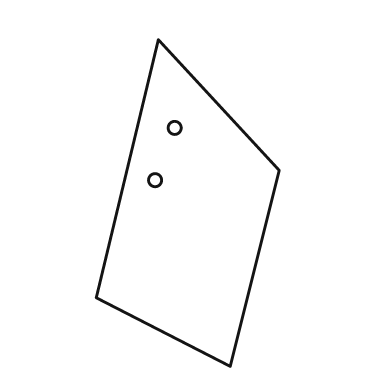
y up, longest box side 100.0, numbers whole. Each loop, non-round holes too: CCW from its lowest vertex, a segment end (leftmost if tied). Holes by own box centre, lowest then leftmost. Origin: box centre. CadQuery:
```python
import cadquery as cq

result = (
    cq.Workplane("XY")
    .moveTo(13.0, -50.0)
    .lineTo(28.0, 10.0)
    .lineTo(-9.0, 50.0)
    .lineTo(-28.0, -29.0)
    .close()
    .moveTo(-10.0, 7.0)
    .circle(2.0)
    .moveTo(-4.0, 23.0)
    .circle(2.0)
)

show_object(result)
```